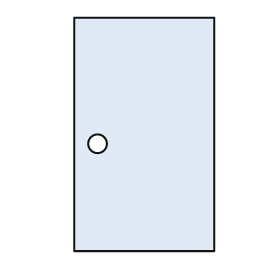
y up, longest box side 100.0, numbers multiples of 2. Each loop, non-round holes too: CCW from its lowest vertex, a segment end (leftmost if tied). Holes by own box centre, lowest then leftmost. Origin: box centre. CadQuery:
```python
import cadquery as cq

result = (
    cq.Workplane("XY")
    .moveTo(-30.0, -50.0)
    .lineTo(30.0, -50.0)
    .lineTo(30.0, 50.0)
    .lineTo(-30.0, 50.0)
    .close()
    .moveTo(-20.0, -4.0)
    .circle(4.0)
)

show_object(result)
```